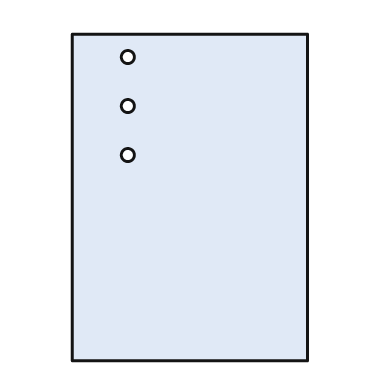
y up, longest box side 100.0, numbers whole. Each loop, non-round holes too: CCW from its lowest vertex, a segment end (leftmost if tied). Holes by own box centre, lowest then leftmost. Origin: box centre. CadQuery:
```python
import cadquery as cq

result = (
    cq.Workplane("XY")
    .moveTo(-36.0, -50.0)
    .lineTo(36.0, -50.0)
    .lineTo(36.0, 50.0)
    .lineTo(-36.0, 50.0)
    .close()
    .moveTo(-19.0, 13.0)
    .circle(2.0)
    .moveTo(-19.0, 28.0)
    .circle(2.0)
    .moveTo(-19.0, 43.0)
    .circle(2.0)
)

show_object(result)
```